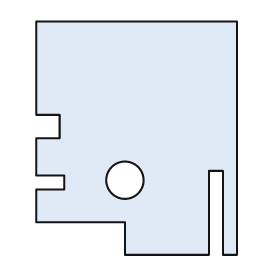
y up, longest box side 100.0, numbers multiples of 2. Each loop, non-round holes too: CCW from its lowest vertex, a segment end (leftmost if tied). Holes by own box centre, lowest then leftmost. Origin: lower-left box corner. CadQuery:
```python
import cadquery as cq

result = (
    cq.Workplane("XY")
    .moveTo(38.0, 0.0)
    .lineTo(74.0, 0.0)
    .lineTo(74.0, 36.0)
    .lineTo(80.0, 36.0)
    .lineTo(80.0, 0.0)
    .lineTo(86.0, 0.0)
    .lineTo(86.0, 100.0)
    .lineTo(0.0, 100.0)
    .lineTo(0.0, 60.0)
    .lineTo(10.0, 60.0)
    .lineTo(10.0, 50.0)
    .lineTo(0.0, 50.0)
    .lineTo(0.0, 34.0)
    .lineTo(12.0, 34.0)
    .lineTo(12.0, 28.0)
    .lineTo(0.0, 28.0)
    .lineTo(0.0, 14.0)
    .lineTo(38.0, 14.0)
    .close()
    .moveTo(38.0, 32.0)
    .circle(8.0)
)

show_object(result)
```